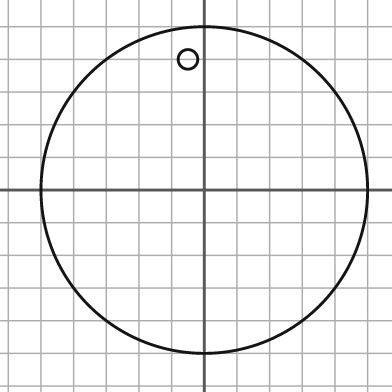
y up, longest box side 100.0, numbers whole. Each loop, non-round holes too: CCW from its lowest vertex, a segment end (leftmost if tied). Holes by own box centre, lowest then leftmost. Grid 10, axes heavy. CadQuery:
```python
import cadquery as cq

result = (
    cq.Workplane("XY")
    .moveTo(0.0, 0.0)
    .circle(50.0)
    .moveTo(-5.0, 40.0)
    .circle(3.0)
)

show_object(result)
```